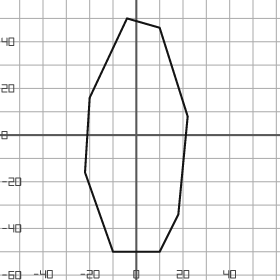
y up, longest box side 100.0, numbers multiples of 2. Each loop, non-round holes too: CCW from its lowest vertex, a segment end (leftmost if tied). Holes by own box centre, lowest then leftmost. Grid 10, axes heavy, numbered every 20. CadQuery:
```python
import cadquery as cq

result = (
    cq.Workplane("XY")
    .moveTo(-10.0, -50.0)
    .lineTo(10.0, -50.0)
    .lineTo(18.0, -34.0)
    .lineTo(22.0, 8.0)
    .lineTo(10.0, 46.0)
    .lineTo(-4.0, 50.0)
    .lineTo(-20.0, 16.0)
    .lineTo(-22.0, -16.0)
    .close()
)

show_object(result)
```